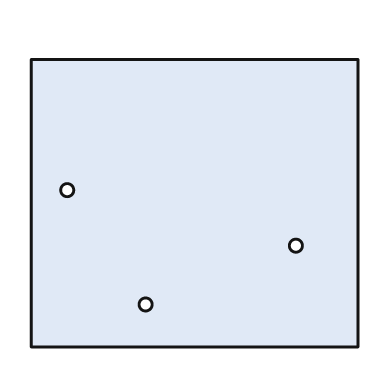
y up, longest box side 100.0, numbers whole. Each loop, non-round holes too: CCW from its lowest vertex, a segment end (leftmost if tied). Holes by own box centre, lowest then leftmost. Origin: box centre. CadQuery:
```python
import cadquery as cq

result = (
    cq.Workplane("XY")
    .moveTo(-50.0, -44.0)
    .lineTo(50.0, -44.0)
    .lineTo(50.0, 44.0)
    .lineTo(-50.0, 44.0)
    .close()
    .moveTo(-15.0, -31.0)
    .circle(2.0)
    .moveTo(31.0, -13.0)
    .circle(2.0)
    .moveTo(-39.0, 4.0)
    .circle(2.0)
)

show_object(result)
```